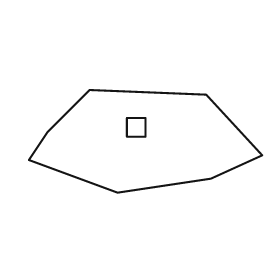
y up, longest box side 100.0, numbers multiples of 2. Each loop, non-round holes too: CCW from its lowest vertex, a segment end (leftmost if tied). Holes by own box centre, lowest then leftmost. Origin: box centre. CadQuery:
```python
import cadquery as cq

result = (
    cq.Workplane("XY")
    .moveTo(-12.0, -22.0)
    .lineTo(28.0, -16.0)
    .lineTo(50.0, -6.0)
    .lineTo(26.0, 20.0)
    .lineTo(-24.0, 22.0)
    .lineTo(-42.0, 4.0)
    .lineTo(-50.0, -8.0)
    .close()
    .moveTo(-8.0, 2.0)
    .lineTo(0.0, 2.0)
    .lineTo(0.0, 10.0)
    .lineTo(-8.0, 10.0)
    .close()
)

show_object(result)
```